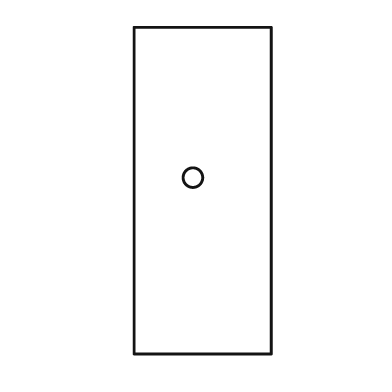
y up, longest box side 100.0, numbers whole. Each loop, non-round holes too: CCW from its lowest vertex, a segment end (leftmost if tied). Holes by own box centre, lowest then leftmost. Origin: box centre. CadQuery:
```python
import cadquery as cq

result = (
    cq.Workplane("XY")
    .moveTo(-21.0, -50.0)
    .lineTo(21.0, -50.0)
    .lineTo(21.0, 50.0)
    .lineTo(-21.0, 50.0)
    .close()
    .moveTo(-3.0, 4.0)
    .circle(3.0)
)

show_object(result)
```